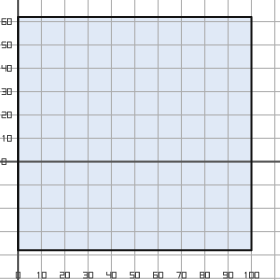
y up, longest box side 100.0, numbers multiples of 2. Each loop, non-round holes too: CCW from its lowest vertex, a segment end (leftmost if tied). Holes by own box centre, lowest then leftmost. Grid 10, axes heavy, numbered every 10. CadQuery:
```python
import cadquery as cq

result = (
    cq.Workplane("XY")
    .moveTo(0.0, -38.0)
    .lineTo(100.0, -38.0)
    .lineTo(100.0, 62.0)
    .lineTo(0.0, 62.0)
    .close()
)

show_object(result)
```